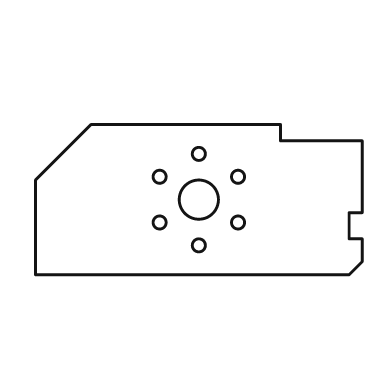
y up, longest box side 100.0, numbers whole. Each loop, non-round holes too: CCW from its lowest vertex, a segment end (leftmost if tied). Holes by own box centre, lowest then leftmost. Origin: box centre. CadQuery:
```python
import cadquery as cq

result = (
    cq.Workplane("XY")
    .moveTo(-50.0, -23.0)
    .lineTo(46.0, -23.0)
    .lineTo(50.0, -19.0)
    .lineTo(50.0, -12.0)
    .lineTo(46.0, -12.0)
    .lineTo(46.0, -4.0)
    .lineTo(50.0, -4.0)
    .lineTo(50.0, 18.0)
    .lineTo(25.0, 18.0)
    .lineTo(25.0, 23.0)
    .lineTo(-33.0, 23.0)
    .lineTo(-50.0, 6.0)
    .close()
    .moveTo(0.0, -14.0)
    .circle(2.0)
    .moveTo(-12.0, -7.0)
    .circle(2.0)
    .moveTo(12.0, -7.0)
    .circle(2.0)
    .moveTo(0.0, 0.0)
    .circle(6.0)
    .moveTo(-12.0, 7.0)
    .circle(2.0)
    .moveTo(12.0, 7.0)
    .circle(2.0)
    .moveTo(0.0, 14.0)
    .circle(2.0)
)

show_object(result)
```